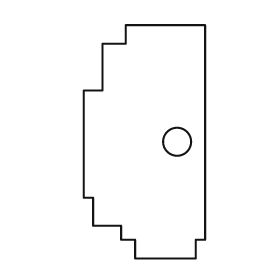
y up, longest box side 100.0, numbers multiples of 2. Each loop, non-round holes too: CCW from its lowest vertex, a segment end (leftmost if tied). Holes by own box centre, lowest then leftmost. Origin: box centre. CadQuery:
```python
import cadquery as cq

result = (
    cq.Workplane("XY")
    .moveTo(-4.0, -50.0)
    .lineTo(22.0, -50.0)
    .lineTo(22.0, -42.0)
    .lineTo(26.0, -42.0)
    .lineTo(26.0, 50.0)
    .lineTo(-8.0, 50.0)
    .lineTo(-8.0, 42.0)
    .lineTo(-18.0, 42.0)
    .lineTo(-18.0, 22.0)
    .lineTo(-26.0, 22.0)
    .lineTo(-26.0, -24.0)
    .lineTo(-22.0, -24.0)
    .lineTo(-22.0, -36.0)
    .lineTo(-10.0, -36.0)
    .lineTo(-10.0, -42.0)
    .lineTo(-4.0, -42.0)
    .close()
    .moveTo(14.0, 0.0)
    .circle(6.0)
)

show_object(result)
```